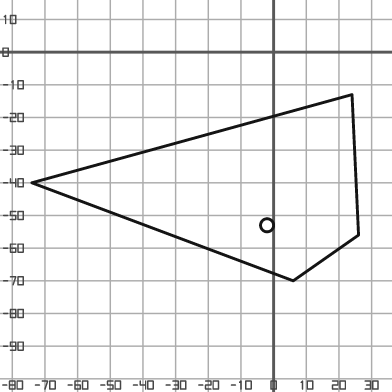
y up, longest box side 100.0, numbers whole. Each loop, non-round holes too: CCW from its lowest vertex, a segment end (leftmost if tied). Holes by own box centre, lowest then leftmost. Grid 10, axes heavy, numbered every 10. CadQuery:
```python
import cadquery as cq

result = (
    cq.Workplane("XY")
    .moveTo(6.0, -70.0)
    .lineTo(26.0, -56.0)
    .lineTo(24.0, -13.0)
    .lineTo(-74.0, -40.0)
    .close()
    .moveTo(-2.0, -53.0)
    .circle(2.0)
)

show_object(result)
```